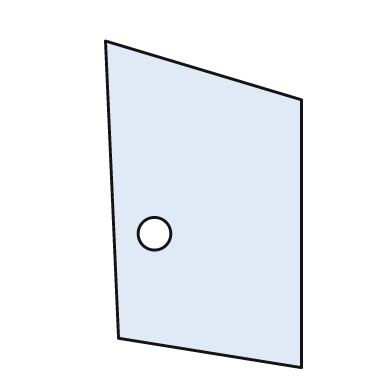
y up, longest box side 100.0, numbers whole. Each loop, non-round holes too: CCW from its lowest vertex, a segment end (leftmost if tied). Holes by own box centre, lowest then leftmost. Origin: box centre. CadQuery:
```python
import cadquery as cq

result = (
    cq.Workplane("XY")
    .moveTo(30.0, -50.0)
    .lineTo(30.0, 32.0)
    .lineTo(-30.0, 50.0)
    .lineTo(-26.0, -41.0)
    .close()
    .moveTo(-15.0, -9.0)
    .circle(5.0)
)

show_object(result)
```